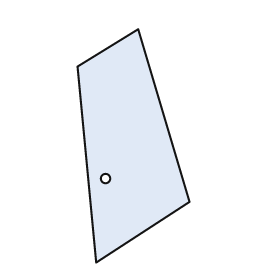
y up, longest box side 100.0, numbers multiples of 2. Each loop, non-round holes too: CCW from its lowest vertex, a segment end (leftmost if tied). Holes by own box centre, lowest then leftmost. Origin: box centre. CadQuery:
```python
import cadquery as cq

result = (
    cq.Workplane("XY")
    .moveTo(-16.0, -50.0)
    .lineTo(24.0, -24.0)
    .lineTo(2.0, 50.0)
    .lineTo(-24.0, 34.0)
    .close()
    .moveTo(-12.0, -14.0)
    .circle(2.0)
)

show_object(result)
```